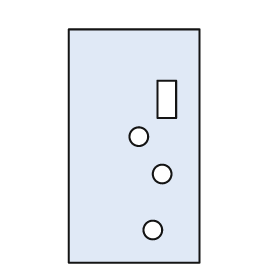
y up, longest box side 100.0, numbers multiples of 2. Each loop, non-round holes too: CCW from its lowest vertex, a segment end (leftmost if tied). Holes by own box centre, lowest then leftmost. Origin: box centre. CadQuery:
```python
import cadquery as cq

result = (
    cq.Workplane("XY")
    .moveTo(-28.0, -50.0)
    .lineTo(28.0, -50.0)
    .lineTo(28.0, 50.0)
    .lineTo(-28.0, 50.0)
    .close()
    .moveTo(8.0, -36.0)
    .circle(4.0)
    .moveTo(12.0, -12.0)
    .circle(4.0)
    .moveTo(2.0, 4.0)
    .circle(4.0)
    .moveTo(10.0, 12.0)
    .lineTo(18.0, 12.0)
    .lineTo(18.0, 28.0)
    .lineTo(10.0, 28.0)
    .close()
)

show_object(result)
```